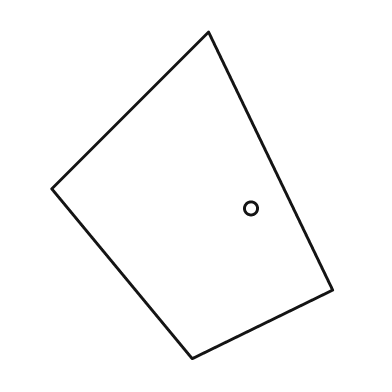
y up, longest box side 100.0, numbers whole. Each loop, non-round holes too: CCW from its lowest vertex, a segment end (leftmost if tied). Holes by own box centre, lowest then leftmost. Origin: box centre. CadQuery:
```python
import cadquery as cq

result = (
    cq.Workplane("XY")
    .moveTo(0.0, -50.0)
    .lineTo(43.0, -29.0)
    .lineTo(5.0, 50.0)
    .lineTo(-43.0, 2.0)
    .close()
    .moveTo(18.0, -4.0)
    .circle(2.0)
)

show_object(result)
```